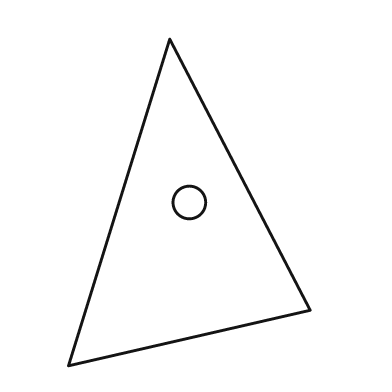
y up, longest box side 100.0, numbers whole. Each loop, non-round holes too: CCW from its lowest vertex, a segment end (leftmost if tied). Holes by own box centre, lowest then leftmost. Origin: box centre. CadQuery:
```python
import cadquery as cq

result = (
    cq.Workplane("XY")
    .moveTo(-37.0, -50.0)
    .lineTo(37.0, -33.0)
    .lineTo(-6.0, 50.0)
    .close()
    .moveTo(0.0, 0.0)
    .circle(5.0)
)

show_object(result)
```